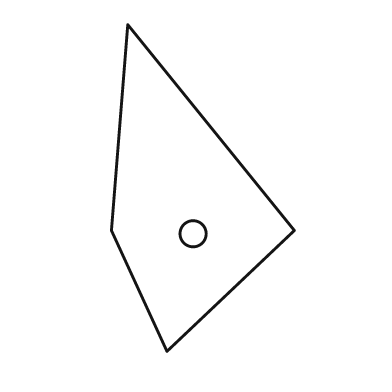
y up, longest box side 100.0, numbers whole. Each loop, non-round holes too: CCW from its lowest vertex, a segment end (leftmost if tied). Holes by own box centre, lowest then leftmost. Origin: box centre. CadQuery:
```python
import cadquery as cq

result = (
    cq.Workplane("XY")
    .moveTo(-11.0, -50.0)
    .lineTo(28.0, -13.0)
    .lineTo(-23.0, 50.0)
    .lineTo(-28.0, -13.0)
    .close()
    .moveTo(-3.0, -14.0)
    .circle(4.0)
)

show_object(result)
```